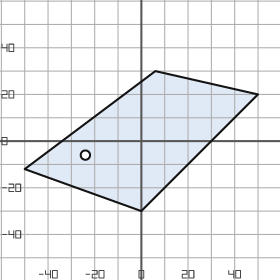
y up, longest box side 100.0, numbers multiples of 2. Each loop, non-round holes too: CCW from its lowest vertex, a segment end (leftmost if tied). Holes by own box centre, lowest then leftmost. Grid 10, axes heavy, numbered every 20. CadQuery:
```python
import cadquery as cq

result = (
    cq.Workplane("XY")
    .moveTo(0.0, -30.0)
    .lineTo(50.0, 20.0)
    .lineTo(6.0, 30.0)
    .lineTo(-50.0, -12.0)
    .close()
    .moveTo(-24.0, -6.0)
    .circle(2.0)
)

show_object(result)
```